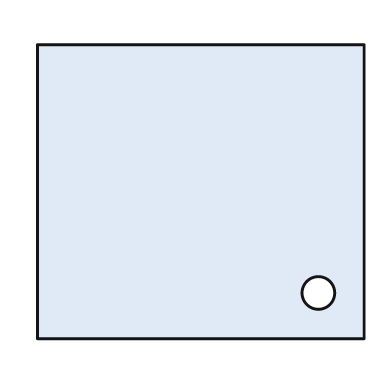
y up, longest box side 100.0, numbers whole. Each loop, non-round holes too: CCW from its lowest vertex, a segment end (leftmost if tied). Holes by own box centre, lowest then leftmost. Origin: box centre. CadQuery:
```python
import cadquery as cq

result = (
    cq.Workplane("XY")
    .moveTo(-50.0, -45.0)
    .lineTo(50.0, -45.0)
    .lineTo(50.0, 45.0)
    .lineTo(-50.0, 45.0)
    .close()
    .moveTo(36.0, -31.0)
    .circle(5.0)
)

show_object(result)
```